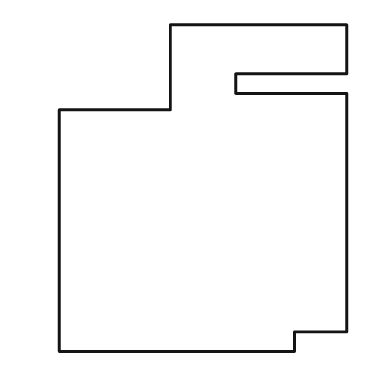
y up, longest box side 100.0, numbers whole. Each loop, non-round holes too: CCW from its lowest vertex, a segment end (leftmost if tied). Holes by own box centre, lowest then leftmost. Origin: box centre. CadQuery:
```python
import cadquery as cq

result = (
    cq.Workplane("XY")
    .moveTo(-44.0, -50.0)
    .lineTo(28.0, -50.0)
    .lineTo(28.0, -44.0)
    .lineTo(44.0, -44.0)
    .lineTo(44.0, 29.0)
    .lineTo(10.0, 29.0)
    .lineTo(10.0, 35.0)
    .lineTo(44.0, 35.0)
    .lineTo(44.0, 50.0)
    .lineTo(-10.0, 50.0)
    .lineTo(-10.0, 24.0)
    .lineTo(-44.0, 24.0)
    .close()
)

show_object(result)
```